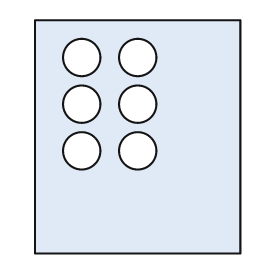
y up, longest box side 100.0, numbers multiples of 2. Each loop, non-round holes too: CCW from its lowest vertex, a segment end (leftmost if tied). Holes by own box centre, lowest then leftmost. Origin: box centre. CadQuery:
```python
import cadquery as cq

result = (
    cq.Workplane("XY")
    .moveTo(-44.0, -50.0)
    .lineTo(44.0, -50.0)
    .lineTo(44.0, 50.0)
    .lineTo(-44.0, 50.0)
    .close()
    .moveTo(-24.0, -6.0)
    .circle(8.0)
    .moveTo(0.0, -6.0)
    .circle(8.0)
    .moveTo(-24.0, 14.0)
    .circle(8.0)
    .moveTo(0.0, 14.0)
    .circle(8.0)
    .moveTo(-24.0, 34.0)
    .circle(8.0)
    .moveTo(0.0, 34.0)
    .circle(8.0)
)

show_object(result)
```